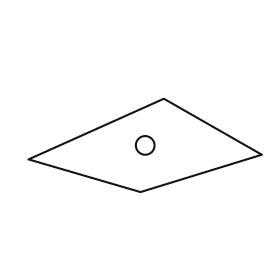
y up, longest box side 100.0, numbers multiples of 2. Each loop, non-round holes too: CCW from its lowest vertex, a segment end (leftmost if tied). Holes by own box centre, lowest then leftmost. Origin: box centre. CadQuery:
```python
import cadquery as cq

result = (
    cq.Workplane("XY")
    .moveTo(-2.0, -20.0)
    .lineTo(50.0, -4.0)
    .lineTo(8.0, 20.0)
    .lineTo(-50.0, -6.0)
    .close()
    .moveTo(0.0, 0.0)
    .circle(4.0)
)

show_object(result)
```